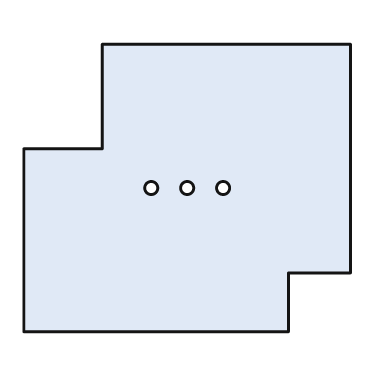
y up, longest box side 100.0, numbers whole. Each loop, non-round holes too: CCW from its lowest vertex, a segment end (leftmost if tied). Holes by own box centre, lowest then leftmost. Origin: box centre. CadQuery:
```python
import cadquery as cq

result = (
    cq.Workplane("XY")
    .moveTo(-50.0, -44.0)
    .lineTo(31.0, -44.0)
    .lineTo(31.0, -26.0)
    .lineTo(50.0, -26.0)
    .lineTo(50.0, 44.0)
    .lineTo(-26.0, 44.0)
    .lineTo(-26.0, 12.0)
    .lineTo(-50.0, 12.0)
    .close()
    .moveTo(-11.0, 0.0)
    .circle(2.0)
    .moveTo(0.0, 0.0)
    .circle(2.0)
    .moveTo(11.0, 0.0)
    .circle(2.0)
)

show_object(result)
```